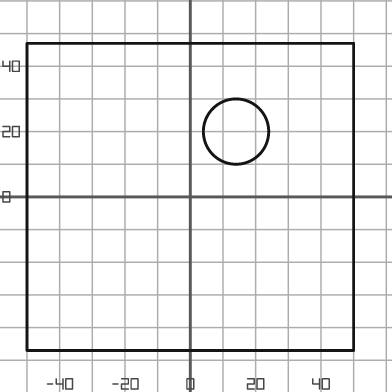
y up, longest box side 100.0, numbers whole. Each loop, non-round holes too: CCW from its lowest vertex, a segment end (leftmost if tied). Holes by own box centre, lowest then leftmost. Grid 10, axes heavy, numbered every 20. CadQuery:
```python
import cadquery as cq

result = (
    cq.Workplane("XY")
    .moveTo(-50.0, -47.0)
    .lineTo(50.0, -47.0)
    .lineTo(50.0, 47.0)
    .lineTo(-50.0, 47.0)
    .close()
    .moveTo(14.0, 20.0)
    .circle(10.0)
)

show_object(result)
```